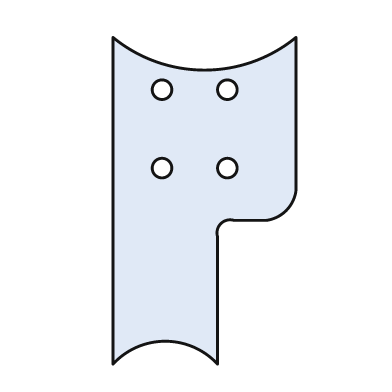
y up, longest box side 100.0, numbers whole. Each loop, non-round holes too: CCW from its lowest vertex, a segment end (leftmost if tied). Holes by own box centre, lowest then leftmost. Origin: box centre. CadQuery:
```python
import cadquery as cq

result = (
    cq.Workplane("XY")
    .moveTo(-28.0, -50.0)
    .threePointArc((-12.0, -43.0), (4.0, -50.0))
    .lineTo(4.0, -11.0)
    .threePointArc((5.0, -7.0), (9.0, -6.0))
    .lineTo(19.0, -6.0)
    .threePointArc((25.0, -3.0), (28.0, 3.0))
    .lineTo(28.0, 50.0)
    .threePointArc((0.0, 40.0), (-28.0, 50.0))
    .close()
    .moveTo(-13.0, 10.0)
    .circle(3.0)
    .moveTo(7.0, 10.0)
    .circle(3.0)
    .moveTo(-13.0, 34.0)
    .circle(3.0)
    .moveTo(7.0, 34.0)
    .circle(3.0)
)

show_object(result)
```